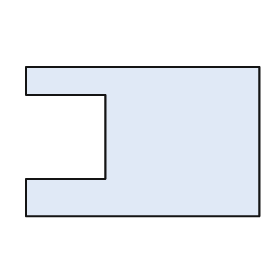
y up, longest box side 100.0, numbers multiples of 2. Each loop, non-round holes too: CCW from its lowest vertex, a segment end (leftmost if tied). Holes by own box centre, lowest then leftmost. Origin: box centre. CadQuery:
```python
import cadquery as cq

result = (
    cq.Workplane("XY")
    .moveTo(-50.0, -32.0)
    .lineTo(50.0, -32.0)
    .lineTo(50.0, 32.0)
    .lineTo(-50.0, 32.0)
    .lineTo(-50.0, 20.0)
    .lineTo(-16.0, 20.0)
    .lineTo(-16.0, -16.0)
    .lineTo(-50.0, -16.0)
    .close()
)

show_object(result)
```